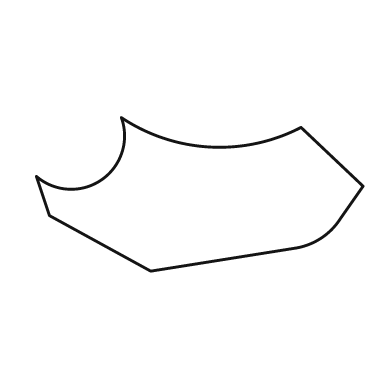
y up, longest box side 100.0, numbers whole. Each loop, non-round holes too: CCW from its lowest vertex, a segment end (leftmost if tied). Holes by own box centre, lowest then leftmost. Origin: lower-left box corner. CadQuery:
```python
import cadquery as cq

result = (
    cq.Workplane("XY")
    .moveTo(35.0, 0.0)
    .lineTo(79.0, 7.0)
    .threePointArc((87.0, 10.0), (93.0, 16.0))
    .lineTo(100.0, 26.0)
    .lineTo(81.0, 44.0)
    .threePointArc((53.0, 38.0), (26.0, 47.0))
    .threePointArc((20.0, 28.0), (0.0, 29.0))
    .lineTo(4.0, 17.0)
    .close()
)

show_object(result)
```